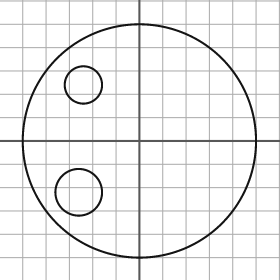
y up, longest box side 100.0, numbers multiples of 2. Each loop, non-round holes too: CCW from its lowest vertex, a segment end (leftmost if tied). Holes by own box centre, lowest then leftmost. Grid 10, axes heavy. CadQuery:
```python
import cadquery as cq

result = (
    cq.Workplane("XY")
    .moveTo(0.0, 0.0)
    .circle(50.0)
    .moveTo(-26.0, -22.0)
    .circle(10.0)
    .moveTo(-24.0, 24.0)
    .circle(8.0)
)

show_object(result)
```